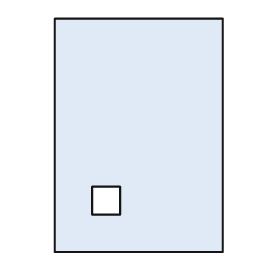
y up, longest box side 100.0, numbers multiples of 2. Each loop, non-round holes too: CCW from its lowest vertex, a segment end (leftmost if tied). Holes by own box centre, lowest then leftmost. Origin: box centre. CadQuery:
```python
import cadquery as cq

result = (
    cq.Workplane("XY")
    .moveTo(-36.0, -50.0)
    .lineTo(36.0, -50.0)
    .lineTo(36.0, 50.0)
    .lineTo(-36.0, 50.0)
    .close()
    .moveTo(-20.0, -34.0)
    .lineTo(-8.0, -34.0)
    .lineTo(-8.0, -22.0)
    .lineTo(-20.0, -22.0)
    .close()
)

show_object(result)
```